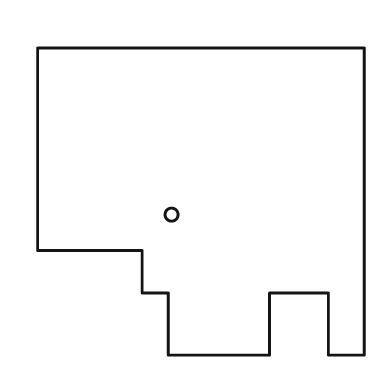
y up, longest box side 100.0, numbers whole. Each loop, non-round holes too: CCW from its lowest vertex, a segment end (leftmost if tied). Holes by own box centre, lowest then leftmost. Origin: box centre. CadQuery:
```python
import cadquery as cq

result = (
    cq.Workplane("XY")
    .moveTo(-10.0, -47.0)
    .lineTo(21.0, -47.0)
    .lineTo(21.0, -28.0)
    .lineTo(39.0, -28.0)
    .lineTo(39.0, -47.0)
    .lineTo(50.0, -47.0)
    .lineTo(50.0, 47.0)
    .lineTo(-50.0, 47.0)
    .lineTo(-50.0, -15.0)
    .lineTo(-18.0, -15.0)
    .lineTo(-18.0, -28.0)
    .lineTo(-10.0, -28.0)
    .close()
    .moveTo(-9.0, -4.0)
    .circle(2.0)
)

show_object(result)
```